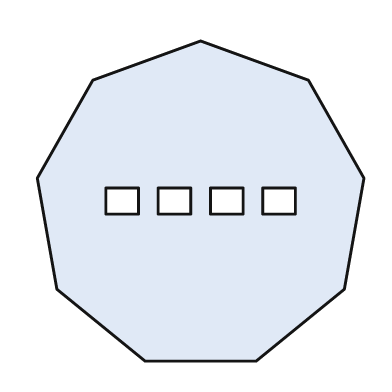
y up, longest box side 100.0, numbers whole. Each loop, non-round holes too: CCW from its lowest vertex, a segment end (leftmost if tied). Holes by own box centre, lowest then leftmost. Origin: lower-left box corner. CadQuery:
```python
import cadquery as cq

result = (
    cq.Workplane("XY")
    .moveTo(33.0, 0.0)
    .lineTo(67.0, 0.0)
    .lineTo(94.0, 22.0)
    .lineTo(100.0, 56.0)
    .lineTo(83.0, 86.0)
    .lineTo(50.0, 98.0)
    .lineTo(17.0, 86.0)
    .lineTo(0.0, 56.0)
    .lineTo(6.0, 22.0)
    .close()
    .moveTo(21.0, 45.0)
    .lineTo(31.0, 45.0)
    .lineTo(31.0, 53.0)
    .lineTo(21.0, 53.0)
    .close()
    .moveTo(37.0, 45.0)
    .lineTo(47.0, 45.0)
    .lineTo(47.0, 53.0)
    .lineTo(37.0, 53.0)
    .close()
    .moveTo(53.0, 45.0)
    .lineTo(63.0, 45.0)
    .lineTo(63.0, 53.0)
    .lineTo(53.0, 53.0)
    .close()
    .moveTo(69.0, 45.0)
    .lineTo(79.0, 45.0)
    .lineTo(79.0, 53.0)
    .lineTo(69.0, 53.0)
    .close()
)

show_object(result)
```